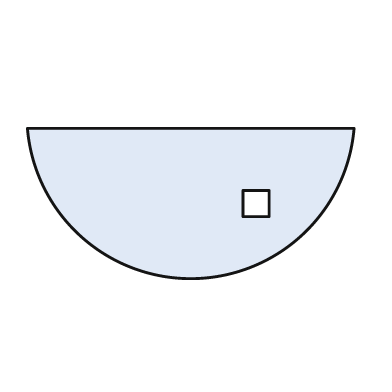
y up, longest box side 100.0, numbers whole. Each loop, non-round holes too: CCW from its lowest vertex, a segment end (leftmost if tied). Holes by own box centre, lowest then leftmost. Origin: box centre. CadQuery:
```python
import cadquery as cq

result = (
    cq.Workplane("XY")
    .moveTo(-50.0, 23.0)
    .threePointArc((0.0, -23.0), (50.0, 23.0))
    .close()
    .moveTo(16.0, -4.0)
    .lineTo(24.0, -4.0)
    .lineTo(24.0, 4.0)
    .lineTo(16.0, 4.0)
    .close()
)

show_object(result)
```